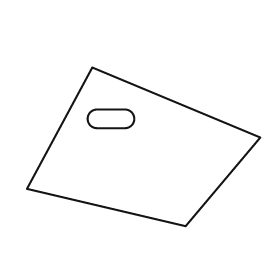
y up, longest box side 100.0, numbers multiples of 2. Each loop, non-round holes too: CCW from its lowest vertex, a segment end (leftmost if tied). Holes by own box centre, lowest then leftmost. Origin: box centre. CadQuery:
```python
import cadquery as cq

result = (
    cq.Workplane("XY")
    .moveTo(18.0, -34.0)
    .lineTo(50.0, 4.0)
    .lineTo(-22.0, 34.0)
    .lineTo(-50.0, -18.0)
    .close()
    .moveTo(-20.0, 8.0)
    .lineTo(-8.0, 8.0)
    .threePointArc((-4.0, 12.0), (-8.0, 16.0))
    .lineTo(-20.0, 16.0)
    .threePointArc((-24.0, 12.0), (-20.0, 8.0))
    .close()
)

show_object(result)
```